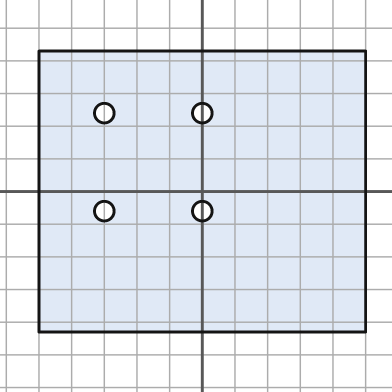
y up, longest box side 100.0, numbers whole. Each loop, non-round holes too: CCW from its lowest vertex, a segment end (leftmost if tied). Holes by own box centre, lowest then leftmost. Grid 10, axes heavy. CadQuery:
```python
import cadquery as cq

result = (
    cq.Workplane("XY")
    .moveTo(-50.0, -43.0)
    .lineTo(50.0, -43.0)
    .lineTo(50.0, 43.0)
    .lineTo(-50.0, 43.0)
    .close()
    .moveTo(-30.0, -6.0)
    .circle(3.0)
    .moveTo(0.0, -6.0)
    .circle(3.0)
    .moveTo(-30.0, 24.0)
    .circle(3.0)
    .moveTo(0.0, 24.0)
    .circle(3.0)
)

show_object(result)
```